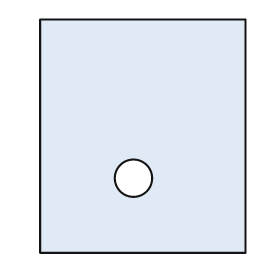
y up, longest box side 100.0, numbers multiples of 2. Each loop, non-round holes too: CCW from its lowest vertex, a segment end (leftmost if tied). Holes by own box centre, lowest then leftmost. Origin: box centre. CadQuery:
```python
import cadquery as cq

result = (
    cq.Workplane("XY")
    .moveTo(-44.0, -50.0)
    .lineTo(44.0, -50.0)
    .lineTo(44.0, 50.0)
    .lineTo(-44.0, 50.0)
    .close()
    .moveTo(-4.0, -18.0)
    .circle(8.0)
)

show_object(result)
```